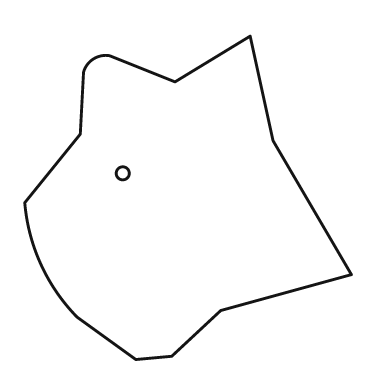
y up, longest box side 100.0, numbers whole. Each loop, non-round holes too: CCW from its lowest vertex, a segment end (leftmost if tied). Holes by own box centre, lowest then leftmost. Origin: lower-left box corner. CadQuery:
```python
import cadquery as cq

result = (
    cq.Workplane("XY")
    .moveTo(34.0, 0.0)
    .lineTo(45.0, 1.0)
    .lineTo(60.0, 15.0)
    .lineTo(100.0, 26.0)
    .lineTo(76.0, 67.0)
    .lineTo(69.0, 99.0)
    .lineTo(46.0, 85.0)
    .lineTo(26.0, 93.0)
    .threePointArc((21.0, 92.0), (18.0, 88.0))
    .lineTo(17.0, 69.0)
    .lineTo(0.0, 48.0)
    .threePointArc((5.0, 29.0), (16.0, 13.0))
    .close()
    .moveTo(30.0, 57.0)
    .circle(2.0)
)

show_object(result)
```